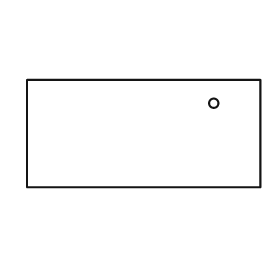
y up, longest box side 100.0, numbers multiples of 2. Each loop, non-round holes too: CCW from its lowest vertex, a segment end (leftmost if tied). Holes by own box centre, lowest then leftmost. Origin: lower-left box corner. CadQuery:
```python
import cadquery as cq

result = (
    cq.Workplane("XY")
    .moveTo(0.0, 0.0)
    .lineTo(100.0, 0.0)
    .lineTo(100.0, 46.0)
    .lineTo(0.0, 46.0)
    .close()
    .moveTo(80.0, 36.0)
    .circle(2.0)
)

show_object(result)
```